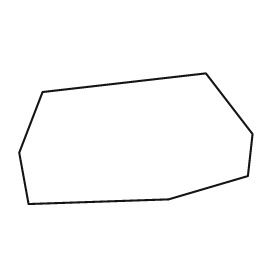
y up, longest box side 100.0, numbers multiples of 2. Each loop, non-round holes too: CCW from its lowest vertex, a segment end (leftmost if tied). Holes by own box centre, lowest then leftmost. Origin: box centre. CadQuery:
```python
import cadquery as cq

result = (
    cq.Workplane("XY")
    .moveTo(-46.0, -28.0)
    .lineTo(14.0, -26.0)
    .lineTo(48.0, -16.0)
    .lineTo(50.0, 2.0)
    .lineTo(30.0, 28.0)
    .lineTo(-40.0, 20.0)
    .lineTo(-50.0, -6.0)
    .close()
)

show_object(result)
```